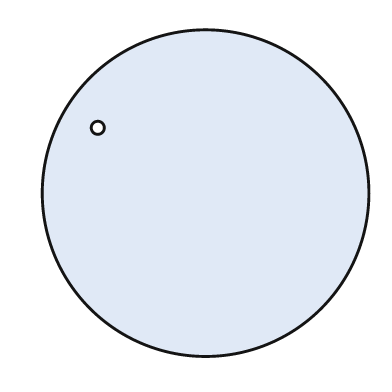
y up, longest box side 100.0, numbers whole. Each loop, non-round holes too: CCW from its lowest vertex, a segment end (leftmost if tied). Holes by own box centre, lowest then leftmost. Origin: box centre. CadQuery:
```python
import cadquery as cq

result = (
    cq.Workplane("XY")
    .moveTo(0.0, 0.0)
    .circle(50.0)
    .moveTo(-33.0, 20.0)
    .circle(2.0)
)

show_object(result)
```